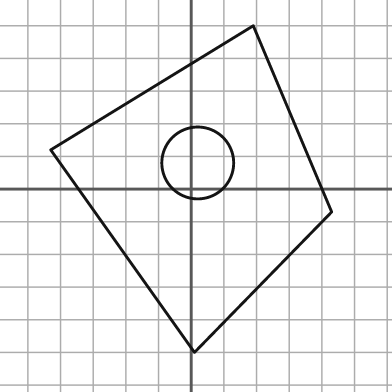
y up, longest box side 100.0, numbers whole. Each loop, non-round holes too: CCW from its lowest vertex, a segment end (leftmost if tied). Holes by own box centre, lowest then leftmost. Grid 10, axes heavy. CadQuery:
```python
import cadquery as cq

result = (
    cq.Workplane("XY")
    .moveTo(1.0, -50.0)
    .lineTo(43.0, -7.0)
    .lineTo(19.0, 50.0)
    .lineTo(-43.0, 12.0)
    .close()
    .moveTo(2.0, 8.0)
    .circle(11.0)
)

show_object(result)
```